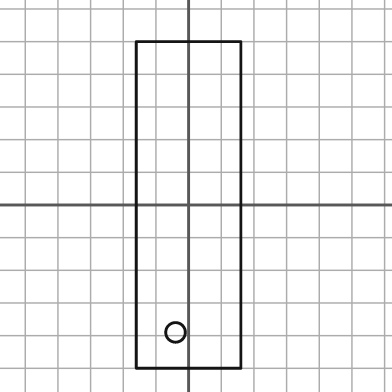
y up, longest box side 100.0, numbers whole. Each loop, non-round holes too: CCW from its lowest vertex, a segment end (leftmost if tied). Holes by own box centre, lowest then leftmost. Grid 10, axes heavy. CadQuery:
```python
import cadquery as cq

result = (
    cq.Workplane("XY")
    .moveTo(-16.0, -50.0)
    .lineTo(16.0, -50.0)
    .lineTo(16.0, 50.0)
    .lineTo(-16.0, 50.0)
    .close()
    .moveTo(-4.0, -39.0)
    .circle(3.0)
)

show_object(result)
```